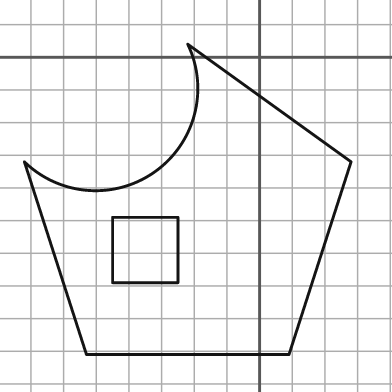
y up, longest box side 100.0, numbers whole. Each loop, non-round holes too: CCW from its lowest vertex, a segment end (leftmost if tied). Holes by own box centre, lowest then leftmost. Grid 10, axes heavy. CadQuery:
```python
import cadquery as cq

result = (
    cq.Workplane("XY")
    .moveTo(-53.0, -91.0)
    .lineTo(9.0, -91.0)
    .lineTo(28.0, -32.0)
    .lineTo(-22.0, 4.0)
    .threePointArc((-32.0, -35.0), (-72.0, -32.0))
    .close()
    .moveTo(-45.0, -69.0)
    .lineTo(-25.0, -69.0)
    .lineTo(-25.0, -49.0)
    .lineTo(-45.0, -49.0)
    .close()
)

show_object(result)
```